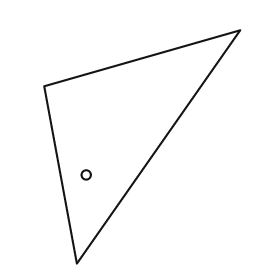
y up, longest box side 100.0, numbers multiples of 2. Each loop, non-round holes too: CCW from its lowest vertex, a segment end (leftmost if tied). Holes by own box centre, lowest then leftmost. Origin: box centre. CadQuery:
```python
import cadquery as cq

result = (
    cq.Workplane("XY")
    .moveTo(-28.0, -50.0)
    .lineTo(42.0, 50.0)
    .lineTo(-42.0, 26.0)
    .close()
    .moveTo(-24.0, -12.0)
    .circle(2.0)
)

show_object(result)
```